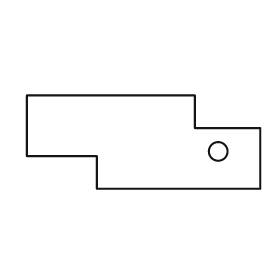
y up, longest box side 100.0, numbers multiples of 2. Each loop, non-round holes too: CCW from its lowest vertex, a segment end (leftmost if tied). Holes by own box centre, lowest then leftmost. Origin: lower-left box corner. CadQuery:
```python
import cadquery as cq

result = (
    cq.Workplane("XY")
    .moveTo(30.0, 0.0)
    .lineTo(100.0, 0.0)
    .lineTo(100.0, 26.0)
    .lineTo(72.0, 26.0)
    .lineTo(72.0, 40.0)
    .lineTo(0.0, 40.0)
    .lineTo(0.0, 14.0)
    .lineTo(30.0, 14.0)
    .close()
    .moveTo(82.0, 16.0)
    .circle(4.0)
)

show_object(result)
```